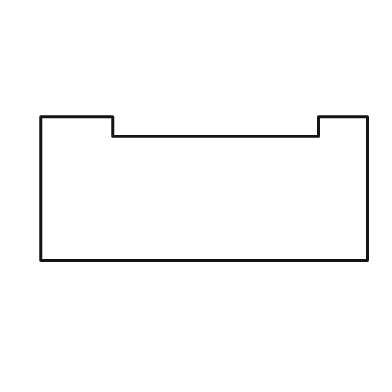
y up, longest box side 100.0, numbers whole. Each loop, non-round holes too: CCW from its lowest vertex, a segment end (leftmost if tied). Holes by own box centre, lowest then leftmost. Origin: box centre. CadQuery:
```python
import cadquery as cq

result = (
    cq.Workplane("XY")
    .moveTo(-50.0, -22.0)
    .lineTo(50.0, -22.0)
    .lineTo(50.0, 22.0)
    .lineTo(35.0, 22.0)
    .lineTo(35.0, 16.0)
    .lineTo(-28.0, 16.0)
    .lineTo(-28.0, 22.0)
    .lineTo(-50.0, 22.0)
    .close()
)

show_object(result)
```